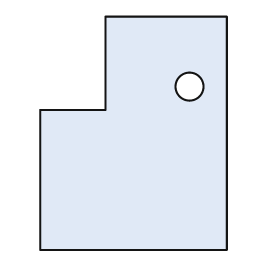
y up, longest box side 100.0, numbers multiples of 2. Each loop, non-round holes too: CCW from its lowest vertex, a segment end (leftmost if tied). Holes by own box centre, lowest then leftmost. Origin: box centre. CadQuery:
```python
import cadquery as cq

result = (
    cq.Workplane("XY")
    .moveTo(-40.0, -50.0)
    .lineTo(40.0, -50.0)
    .lineTo(40.0, 50.0)
    .lineTo(-12.0, 50.0)
    .lineTo(-12.0, 10.0)
    .lineTo(-40.0, 10.0)
    .close()
    .moveTo(24.0, 20.0)
    .circle(6.0)
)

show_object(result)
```